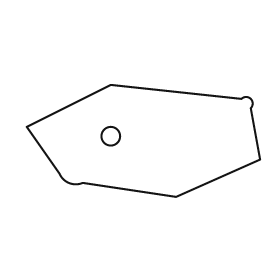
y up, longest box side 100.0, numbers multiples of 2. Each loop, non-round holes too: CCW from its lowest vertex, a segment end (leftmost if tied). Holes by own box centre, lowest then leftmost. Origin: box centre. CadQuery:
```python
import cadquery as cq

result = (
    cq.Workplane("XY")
    .moveTo(14.0, -24.0)
    .lineTo(50.0, -8.0)
    .lineTo(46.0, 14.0)
    .threePointArc((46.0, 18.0), (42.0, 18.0))
    .lineTo(-14.0, 24.0)
    .lineTo(-50.0, 6.0)
    .lineTo(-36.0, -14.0)
    .threePointArc((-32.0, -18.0), (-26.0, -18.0))
    .close()
    .moveTo(-14.0, 2.0)
    .circle(4.0)
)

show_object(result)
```